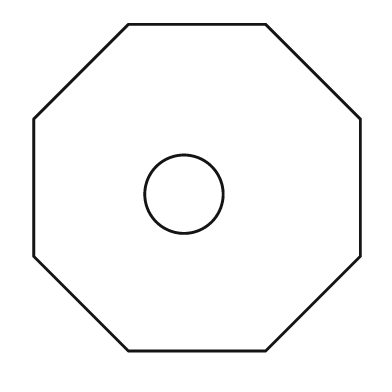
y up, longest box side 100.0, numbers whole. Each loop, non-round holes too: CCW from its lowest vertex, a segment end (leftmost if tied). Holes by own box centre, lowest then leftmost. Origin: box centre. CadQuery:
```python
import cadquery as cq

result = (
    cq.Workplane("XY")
    .moveTo(-21.0, -50.0)
    .lineTo(21.0, -50.0)
    .lineTo(50.0, -21.0)
    .lineTo(50.0, 21.0)
    .lineTo(21.0, 50.0)
    .lineTo(-21.0, 50.0)
    .lineTo(-50.0, 21.0)
    .lineTo(-50.0, -21.0)
    .close()
    .moveTo(-4.0, -2.0)
    .circle(12.0)
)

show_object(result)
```